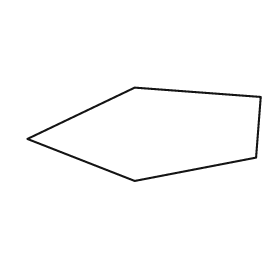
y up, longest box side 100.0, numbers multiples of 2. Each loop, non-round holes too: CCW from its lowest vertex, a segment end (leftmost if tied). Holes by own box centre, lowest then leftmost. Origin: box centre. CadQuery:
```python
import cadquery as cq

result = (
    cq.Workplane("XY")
    .moveTo(-4.0, -20.0)
    .lineTo(48.0, -10.0)
    .lineTo(50.0, 16.0)
    .lineTo(-4.0, 20.0)
    .lineTo(-50.0, -2.0)
    .close()
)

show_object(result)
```